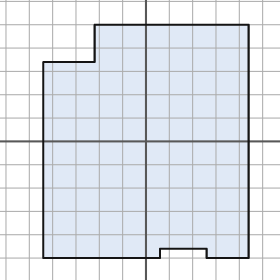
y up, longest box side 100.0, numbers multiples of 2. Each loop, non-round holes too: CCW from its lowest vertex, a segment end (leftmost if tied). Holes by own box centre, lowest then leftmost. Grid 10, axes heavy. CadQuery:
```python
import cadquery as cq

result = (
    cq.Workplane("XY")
    .moveTo(-44.0, -50.0)
    .lineTo(6.0, -50.0)
    .lineTo(6.0, -46.0)
    .lineTo(26.0, -46.0)
    .lineTo(26.0, -50.0)
    .lineTo(44.0, -50.0)
    .lineTo(44.0, 50.0)
    .lineTo(-22.0, 50.0)
    .lineTo(-22.0, 34.0)
    .lineTo(-44.0, 34.0)
    .close()
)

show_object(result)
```